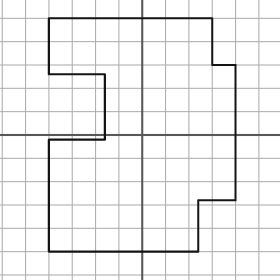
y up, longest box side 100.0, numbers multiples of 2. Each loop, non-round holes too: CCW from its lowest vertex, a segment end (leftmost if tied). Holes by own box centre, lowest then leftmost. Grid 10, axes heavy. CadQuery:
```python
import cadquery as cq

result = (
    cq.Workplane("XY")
    .moveTo(-40.0, -50.0)
    .lineTo(24.0, -50.0)
    .lineTo(24.0, -28.0)
    .lineTo(40.0, -28.0)
    .lineTo(40.0, 30.0)
    .lineTo(30.0, 30.0)
    .lineTo(30.0, 50.0)
    .lineTo(-40.0, 50.0)
    .lineTo(-40.0, 26.0)
    .lineTo(-16.0, 26.0)
    .lineTo(-16.0, -2.0)
    .lineTo(-40.0, -2.0)
    .close()
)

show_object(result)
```